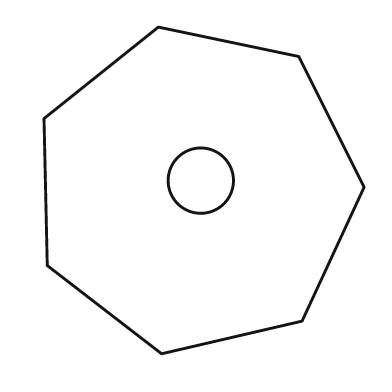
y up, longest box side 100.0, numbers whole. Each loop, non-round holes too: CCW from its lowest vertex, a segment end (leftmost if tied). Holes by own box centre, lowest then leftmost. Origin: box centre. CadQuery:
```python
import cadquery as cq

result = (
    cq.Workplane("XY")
    .moveTo(-13.0, -50.0)
    .lineTo(30.0, -40.0)
    .lineTo(49.0, 1.0)
    .lineTo(29.0, 41.0)
    .lineTo(-14.0, 50.0)
    .lineTo(-49.0, 22.0)
    .lineTo(-48.0, -23.0)
    .close()
    .moveTo(-1.0, 3.0)
    .circle(10.0)
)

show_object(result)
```